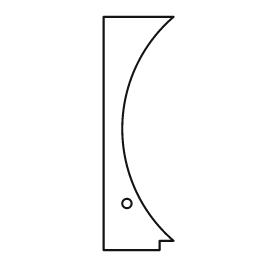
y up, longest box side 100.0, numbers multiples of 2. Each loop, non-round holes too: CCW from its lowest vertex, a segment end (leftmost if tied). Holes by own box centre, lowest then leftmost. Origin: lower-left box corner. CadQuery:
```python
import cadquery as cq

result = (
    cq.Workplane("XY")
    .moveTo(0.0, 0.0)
    .lineTo(24.0, 0.0)
    .lineTo(24.0, 4.0)
    .lineTo(30.0, 4.0)
    .threePointArc((8.0, 52.0), (30.0, 100.0))
    .lineTo(0.0, 100.0)
    .close()
    .moveTo(10.0, 20.0)
    .circle(2.0)
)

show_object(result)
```